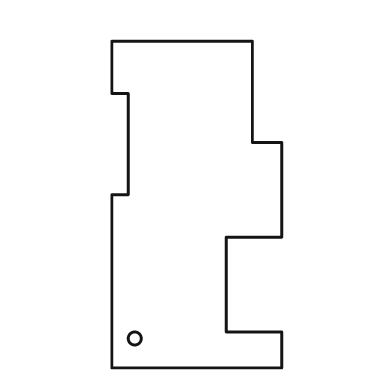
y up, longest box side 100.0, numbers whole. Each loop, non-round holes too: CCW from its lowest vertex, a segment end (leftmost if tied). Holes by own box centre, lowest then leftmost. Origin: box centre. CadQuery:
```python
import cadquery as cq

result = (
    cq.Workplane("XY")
    .moveTo(-26.0, -50.0)
    .lineTo(26.0, -50.0)
    .lineTo(26.0, -39.0)
    .lineTo(9.0, -39.0)
    .lineTo(9.0, -10.0)
    .lineTo(26.0, -10.0)
    .lineTo(26.0, 19.0)
    .lineTo(17.0, 19.0)
    .lineTo(17.0, 50.0)
    .lineTo(-26.0, 50.0)
    .lineTo(-26.0, 34.0)
    .lineTo(-21.0, 34.0)
    .lineTo(-21.0, 3.0)
    .lineTo(-26.0, 3.0)
    .close()
    .moveTo(-19.0, -41.0)
    .circle(2.0)
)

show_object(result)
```